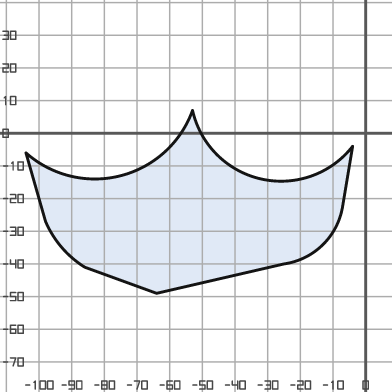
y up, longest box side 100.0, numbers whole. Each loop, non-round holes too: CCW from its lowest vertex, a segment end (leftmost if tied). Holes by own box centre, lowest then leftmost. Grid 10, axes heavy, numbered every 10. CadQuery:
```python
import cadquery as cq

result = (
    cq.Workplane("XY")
    .moveTo(-64.0, -49.0)
    .lineTo(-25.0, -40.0)
    .threePointArc((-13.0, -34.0), (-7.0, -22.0))
    .lineTo(-4.0, -4.0)
    .threePointArc((-32.0, -14.0), (-53.0, 7.0))
    .threePointArc((-75.0, -13.0), (-104.0, -6.0))
    .lineTo(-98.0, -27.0)
    .threePointArc((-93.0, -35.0), (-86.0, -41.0))
    .close()
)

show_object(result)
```